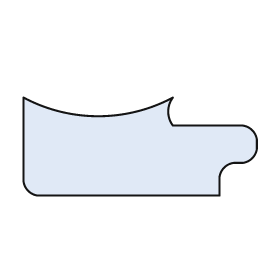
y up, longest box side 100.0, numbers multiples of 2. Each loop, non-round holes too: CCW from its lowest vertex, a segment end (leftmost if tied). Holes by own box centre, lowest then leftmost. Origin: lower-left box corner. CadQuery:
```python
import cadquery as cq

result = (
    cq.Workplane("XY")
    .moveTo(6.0, 0.0)
    .lineTo(84.0, 0.0)
    .lineTo(84.0, 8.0)
    .threePointArc((86.0, 12.0), (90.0, 14.0))
    .lineTo(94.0, 14.0)
    .threePointArc((98.0, 16.0), (100.0, 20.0))
    .lineTo(100.0, 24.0)
    .threePointArc((98.0, 28.0), (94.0, 30.0))
    .lineTo(64.0, 30.0)
    .threePointArc((62.0, 36.0), (64.0, 42.0))
    .threePointArc((32.0, 34.0), (0.0, 42.0))
    .lineTo(0.0, 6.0)
    .threePointArc((2.0, 2.0), (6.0, 0.0))
    .close()
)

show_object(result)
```